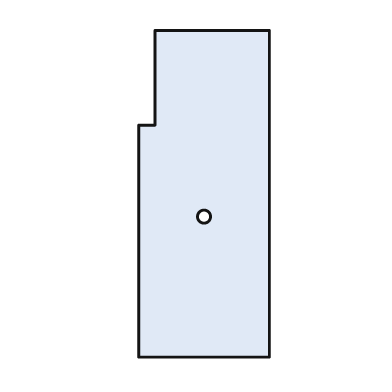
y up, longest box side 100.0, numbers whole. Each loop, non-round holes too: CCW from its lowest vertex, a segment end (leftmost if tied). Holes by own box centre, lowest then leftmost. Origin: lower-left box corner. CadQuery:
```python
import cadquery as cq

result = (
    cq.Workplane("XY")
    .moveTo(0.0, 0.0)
    .lineTo(40.0, 0.0)
    .lineTo(40.0, 100.0)
    .lineTo(5.0, 100.0)
    .lineTo(5.0, 71.0)
    .lineTo(0.0, 71.0)
    .close()
    .moveTo(20.0, 43.0)
    .circle(2.0)
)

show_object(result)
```